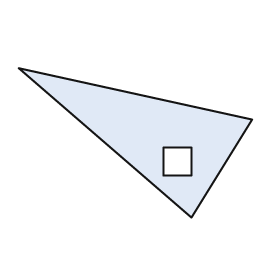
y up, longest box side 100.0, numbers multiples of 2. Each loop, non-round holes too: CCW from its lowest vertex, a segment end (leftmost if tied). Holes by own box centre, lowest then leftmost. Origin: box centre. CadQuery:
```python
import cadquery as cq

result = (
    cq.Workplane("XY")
    .moveTo(24.0, -32.0)
    .lineTo(50.0, 10.0)
    .lineTo(-50.0, 32.0)
    .close()
    .moveTo(12.0, -14.0)
    .lineTo(24.0, -14.0)
    .lineTo(24.0, -2.0)
    .lineTo(12.0, -2.0)
    .close()
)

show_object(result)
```